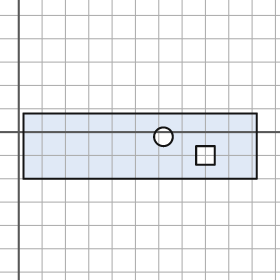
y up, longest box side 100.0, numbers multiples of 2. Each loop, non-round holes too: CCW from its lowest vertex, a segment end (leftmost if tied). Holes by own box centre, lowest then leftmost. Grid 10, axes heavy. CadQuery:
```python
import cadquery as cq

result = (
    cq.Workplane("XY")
    .moveTo(2.0, -20.0)
    .lineTo(102.0, -20.0)
    .lineTo(102.0, 8.0)
    .lineTo(2.0, 8.0)
    .close()
    .moveTo(76.0, -14.0)
    .lineTo(84.0, -14.0)
    .lineTo(84.0, -6.0)
    .lineTo(76.0, -6.0)
    .close()
    .moveTo(62.0, -2.0)
    .circle(4.0)
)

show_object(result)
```